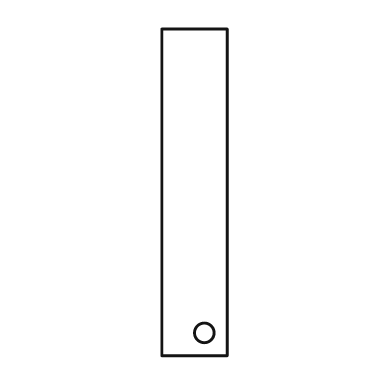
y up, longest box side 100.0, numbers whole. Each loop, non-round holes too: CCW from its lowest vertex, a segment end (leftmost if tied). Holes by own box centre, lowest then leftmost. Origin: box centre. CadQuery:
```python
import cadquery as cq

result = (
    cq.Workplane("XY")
    .moveTo(-10.0, -50.0)
    .lineTo(10.0, -50.0)
    .lineTo(10.0, 50.0)
    .lineTo(-10.0, 50.0)
    .close()
    .moveTo(3.0, -43.0)
    .circle(3.0)
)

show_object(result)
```